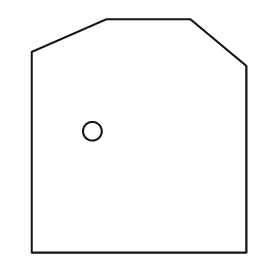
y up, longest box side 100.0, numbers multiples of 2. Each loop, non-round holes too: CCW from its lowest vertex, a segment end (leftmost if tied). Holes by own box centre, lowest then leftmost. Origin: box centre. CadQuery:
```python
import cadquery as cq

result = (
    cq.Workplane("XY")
    .moveTo(-46.0, -50.0)
    .lineTo(46.0, -50.0)
    .lineTo(46.0, 30.0)
    .lineTo(22.0, 50.0)
    .lineTo(-14.0, 50.0)
    .lineTo(-46.0, 36.0)
    .close()
    .moveTo(-20.0, 2.0)
    .circle(4.0)
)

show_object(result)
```